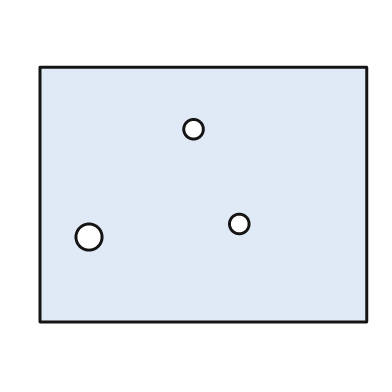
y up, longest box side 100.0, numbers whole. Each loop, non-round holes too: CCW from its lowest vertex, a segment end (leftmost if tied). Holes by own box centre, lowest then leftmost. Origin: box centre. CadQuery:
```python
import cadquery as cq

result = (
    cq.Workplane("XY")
    .moveTo(-50.0, -39.0)
    .lineTo(50.0, -39.0)
    .lineTo(50.0, 39.0)
    .lineTo(-50.0, 39.0)
    .close()
    .moveTo(-35.0, -13.0)
    .circle(4.0)
    .moveTo(11.0, -9.0)
    .circle(3.0)
    .moveTo(-3.0, 20.0)
    .circle(3.0)
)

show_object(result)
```